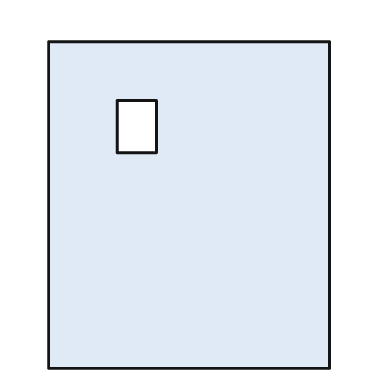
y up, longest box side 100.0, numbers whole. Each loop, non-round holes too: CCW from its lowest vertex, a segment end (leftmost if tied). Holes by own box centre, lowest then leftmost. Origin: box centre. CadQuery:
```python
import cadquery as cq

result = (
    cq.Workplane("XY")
    .moveTo(-43.0, -50.0)
    .lineTo(43.0, -50.0)
    .lineTo(43.0, 50.0)
    .lineTo(-43.0, 50.0)
    .close()
    .moveTo(-22.0, 16.0)
    .lineTo(-10.0, 16.0)
    .lineTo(-10.0, 32.0)
    .lineTo(-22.0, 32.0)
    .close()
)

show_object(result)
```